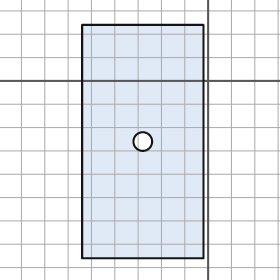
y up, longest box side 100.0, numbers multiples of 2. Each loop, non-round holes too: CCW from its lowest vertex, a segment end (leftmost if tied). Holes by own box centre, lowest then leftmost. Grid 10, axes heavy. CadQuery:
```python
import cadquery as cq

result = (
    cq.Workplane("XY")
    .moveTo(-54.0, -76.0)
    .lineTo(-2.0, -76.0)
    .lineTo(-2.0, 24.0)
    .lineTo(-54.0, 24.0)
    .close()
    .moveTo(-28.0, -26.0)
    .circle(4.0)
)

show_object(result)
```